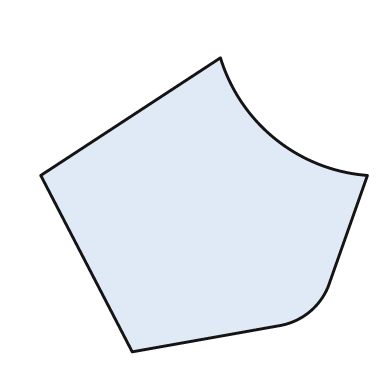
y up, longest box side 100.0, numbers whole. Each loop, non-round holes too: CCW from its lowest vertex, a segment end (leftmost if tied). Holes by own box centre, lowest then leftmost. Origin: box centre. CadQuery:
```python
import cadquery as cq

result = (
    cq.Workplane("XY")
    .moveTo(-22.0, -45.0)
    .lineTo(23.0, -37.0)
    .threePointArc((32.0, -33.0), (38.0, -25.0))
    .lineTo(50.0, 9.0)
    .threePointArc((22.0, 20.0), (5.0, 45.0))
    .lineTo(-50.0, 9.0)
    .close()
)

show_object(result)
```